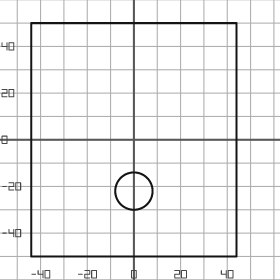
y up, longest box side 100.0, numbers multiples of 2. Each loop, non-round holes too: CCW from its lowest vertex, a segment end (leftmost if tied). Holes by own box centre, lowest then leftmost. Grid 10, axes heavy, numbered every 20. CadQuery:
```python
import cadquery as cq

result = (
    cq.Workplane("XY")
    .moveTo(-44.0, -50.0)
    .lineTo(44.0, -50.0)
    .lineTo(44.0, 50.0)
    .lineTo(-44.0, 50.0)
    .close()
    .moveTo(0.0, -22.0)
    .circle(8.0)
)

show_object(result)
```